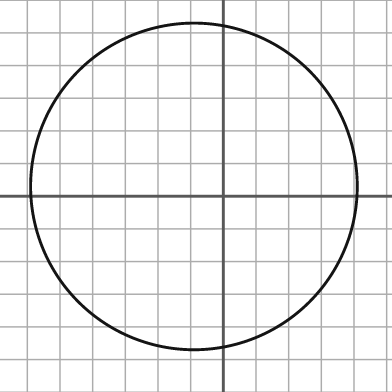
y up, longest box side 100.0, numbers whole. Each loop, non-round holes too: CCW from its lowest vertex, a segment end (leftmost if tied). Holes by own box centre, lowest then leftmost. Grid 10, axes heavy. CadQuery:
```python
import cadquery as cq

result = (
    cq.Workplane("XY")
    .moveTo(-9.0, 3.0)
    .circle(50.0)
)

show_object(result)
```